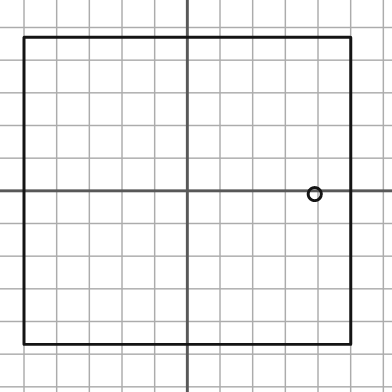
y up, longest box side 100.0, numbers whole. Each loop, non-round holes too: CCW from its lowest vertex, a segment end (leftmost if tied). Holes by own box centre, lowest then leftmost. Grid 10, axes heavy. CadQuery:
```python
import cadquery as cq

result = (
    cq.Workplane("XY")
    .moveTo(-50.0, -47.0)
    .lineTo(50.0, -47.0)
    .lineTo(50.0, 47.0)
    .lineTo(-50.0, 47.0)
    .close()
    .moveTo(39.0, -1.0)
    .circle(2.0)
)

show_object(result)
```